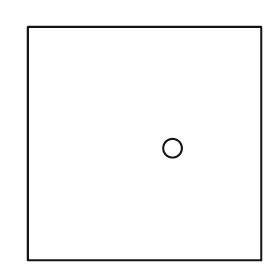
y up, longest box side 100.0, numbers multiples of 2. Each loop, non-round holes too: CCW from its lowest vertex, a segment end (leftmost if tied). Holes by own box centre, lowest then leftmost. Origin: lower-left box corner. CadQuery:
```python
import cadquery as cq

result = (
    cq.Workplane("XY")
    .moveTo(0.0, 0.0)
    .lineTo(100.0, 0.0)
    .lineTo(100.0, 100.0)
    .lineTo(0.0, 100.0)
    .close()
    .moveTo(62.0, 48.0)
    .circle(4.0)
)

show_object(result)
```